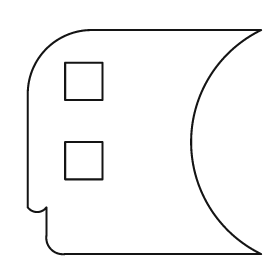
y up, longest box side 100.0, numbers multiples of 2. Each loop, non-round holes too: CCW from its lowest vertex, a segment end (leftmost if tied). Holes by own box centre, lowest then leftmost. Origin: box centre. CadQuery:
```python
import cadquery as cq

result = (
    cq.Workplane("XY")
    .moveTo(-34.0, -48.0)
    .lineTo(50.0, -48.0)
    .threePointArc((20.0, 0.0), (50.0, 48.0))
    .lineTo(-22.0, 48.0)
    .threePointArc((-42.0, 40.0), (-50.0, 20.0))
    .lineTo(-50.0, -28.0)
    .threePointArc((-46.0, -30.0), (-42.0, -28.0))
    .lineTo(-42.0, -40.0)
    .threePointArc((-40.0, -46.0), (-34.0, -48.0))
    .close()
    .moveTo(-34.0, -16.0)
    .lineTo(-18.0, -16.0)
    .lineTo(-18.0, 0.0)
    .lineTo(-34.0, 0.0)
    .close()
    .moveTo(-34.0, 18.0)
    .lineTo(-18.0, 18.0)
    .lineTo(-18.0, 34.0)
    .lineTo(-34.0, 34.0)
    .close()
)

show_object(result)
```